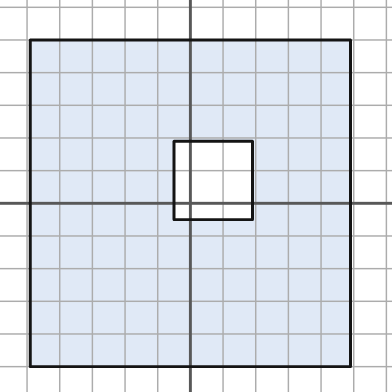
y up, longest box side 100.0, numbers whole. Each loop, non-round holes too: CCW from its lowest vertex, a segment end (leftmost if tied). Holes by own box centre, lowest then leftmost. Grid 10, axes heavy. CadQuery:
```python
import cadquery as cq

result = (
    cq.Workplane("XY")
    .moveTo(-49.0, -50.0)
    .lineTo(49.0, -50.0)
    .lineTo(49.0, 50.0)
    .lineTo(-49.0, 50.0)
    .close()
    .moveTo(-5.0, -5.0)
    .lineTo(19.0, -5.0)
    .lineTo(19.0, 19.0)
    .lineTo(-5.0, 19.0)
    .close()
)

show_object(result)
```